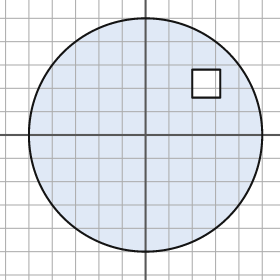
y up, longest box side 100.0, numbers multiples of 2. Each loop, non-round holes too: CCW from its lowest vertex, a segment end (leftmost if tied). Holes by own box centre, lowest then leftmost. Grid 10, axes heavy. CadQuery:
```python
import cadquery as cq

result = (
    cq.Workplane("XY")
    .moveTo(0.0, 0.0)
    .circle(50.0)
    .moveTo(20.0, 16.0)
    .lineTo(32.0, 16.0)
    .lineTo(32.0, 28.0)
    .lineTo(20.0, 28.0)
    .close()
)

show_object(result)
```